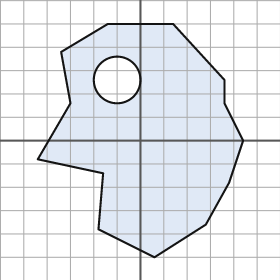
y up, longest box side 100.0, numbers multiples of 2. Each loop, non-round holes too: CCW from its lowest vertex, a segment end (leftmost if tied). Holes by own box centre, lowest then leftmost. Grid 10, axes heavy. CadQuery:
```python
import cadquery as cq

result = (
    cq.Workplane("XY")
    .moveTo(6.0, -50.0)
    .lineTo(28.0, -36.0)
    .lineTo(38.0, -18.0)
    .lineTo(44.0, 0.0)
    .lineTo(36.0, 16.0)
    .lineTo(36.0, 26.0)
    .lineTo(14.0, 50.0)
    .lineTo(-14.0, 50.0)
    .lineTo(-34.0, 38.0)
    .lineTo(-30.0, 16.0)
    .lineTo(-44.0, -8.0)
    .lineTo(-16.0, -14.0)
    .lineTo(-18.0, -38.0)
    .close()
    .moveTo(-10.0, 26.0)
    .circle(10.0)
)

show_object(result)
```